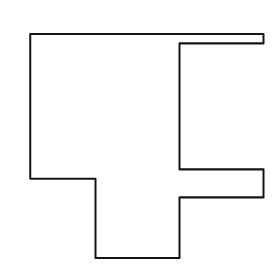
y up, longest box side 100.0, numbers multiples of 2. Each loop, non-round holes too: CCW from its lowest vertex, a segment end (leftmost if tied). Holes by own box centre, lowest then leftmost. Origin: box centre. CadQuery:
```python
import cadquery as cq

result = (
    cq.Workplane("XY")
    .moveTo(-22.0, -48.0)
    .lineTo(14.0, -48.0)
    .lineTo(14.0, -22.0)
    .lineTo(50.0, -22.0)
    .lineTo(50.0, -10.0)
    .lineTo(14.0, -10.0)
    .lineTo(14.0, 44.0)
    .lineTo(50.0, 44.0)
    .lineTo(50.0, 48.0)
    .lineTo(-50.0, 48.0)
    .lineTo(-50.0, -14.0)
    .lineTo(-22.0, -14.0)
    .close()
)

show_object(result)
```